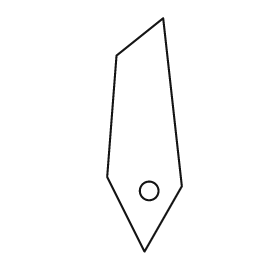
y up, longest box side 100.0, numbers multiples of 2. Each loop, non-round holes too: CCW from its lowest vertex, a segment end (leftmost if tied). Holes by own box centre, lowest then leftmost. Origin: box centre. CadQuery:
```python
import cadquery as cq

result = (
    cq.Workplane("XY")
    .moveTo(0.0, -50.0)
    .lineTo(16.0, -22.0)
    .lineTo(8.0, 50.0)
    .lineTo(-12.0, 34.0)
    .lineTo(-16.0, -18.0)
    .close()
    .moveTo(2.0, -24.0)
    .circle(4.0)
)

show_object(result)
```